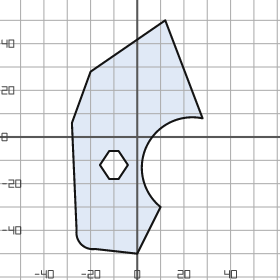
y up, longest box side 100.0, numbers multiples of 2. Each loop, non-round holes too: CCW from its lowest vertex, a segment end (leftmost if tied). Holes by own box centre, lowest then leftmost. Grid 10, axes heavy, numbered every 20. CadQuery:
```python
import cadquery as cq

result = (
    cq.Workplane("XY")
    .moveTo(0.0, -50.0)
    .lineTo(10.0, -30.0)
    .threePointArc((4.0, -4.0), (28.0, 8.0))
    .lineTo(12.0, 50.0)
    .lineTo(-20.0, 28.0)
    .lineTo(-28.0, 6.0)
    .lineTo(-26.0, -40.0)
    .threePointArc((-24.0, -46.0), (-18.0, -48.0))
    .close()
    .moveTo(-12.0, -18.0)
    .lineTo(-8.0, -18.0)
    .lineTo(-4.0, -12.0)
    .lineTo(-8.0, -6.0)
    .lineTo(-12.0, -6.0)
    .lineTo(-16.0, -12.0)
    .close()
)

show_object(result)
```